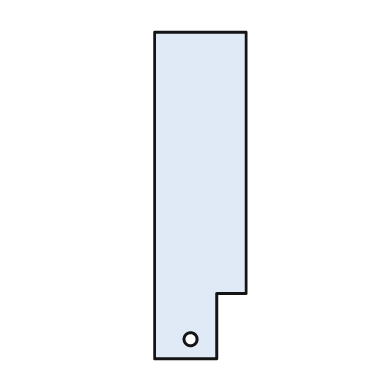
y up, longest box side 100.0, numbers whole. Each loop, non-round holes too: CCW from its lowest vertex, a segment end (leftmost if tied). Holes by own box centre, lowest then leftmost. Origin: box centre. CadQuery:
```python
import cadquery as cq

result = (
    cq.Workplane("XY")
    .moveTo(-14.0, -50.0)
    .lineTo(5.0, -50.0)
    .lineTo(5.0, -30.0)
    .lineTo(14.0, -30.0)
    .lineTo(14.0, 50.0)
    .lineTo(-14.0, 50.0)
    .close()
    .moveTo(-3.0, -44.0)
    .circle(2.0)
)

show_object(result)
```